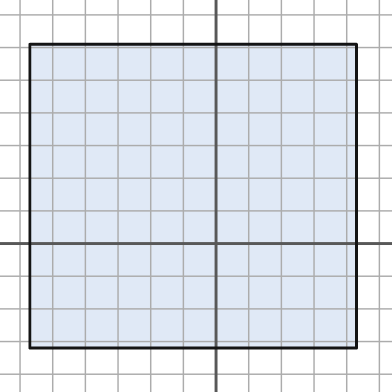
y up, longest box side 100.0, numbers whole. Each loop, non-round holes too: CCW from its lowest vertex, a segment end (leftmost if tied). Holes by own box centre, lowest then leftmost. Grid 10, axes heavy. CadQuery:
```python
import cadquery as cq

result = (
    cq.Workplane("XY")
    .moveTo(-57.0, -32.0)
    .lineTo(43.0, -32.0)
    .lineTo(43.0, 61.0)
    .lineTo(-57.0, 61.0)
    .close()
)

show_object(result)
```